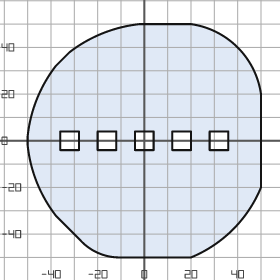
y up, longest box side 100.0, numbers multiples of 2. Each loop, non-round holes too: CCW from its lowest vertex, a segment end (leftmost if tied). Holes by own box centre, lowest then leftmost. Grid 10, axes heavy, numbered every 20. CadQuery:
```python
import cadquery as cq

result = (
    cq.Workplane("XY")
    .moveTo(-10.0, -50.0)
    .lineTo(20.0, -50.0)
    .threePointArc((38.0, -38.0), (50.0, -20.0))
    .lineTo(50.0, 20.0)
    .threePointArc((40.0, 40.0), (20.0, 50.0))
    .lineTo(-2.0, 50.0)
    .threePointArc((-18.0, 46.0), (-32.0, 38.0))
    .lineTo(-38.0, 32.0)
    .threePointArc((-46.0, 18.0), (-50.0, 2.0))
    .lineTo(-50.0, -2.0)
    .threePointArc((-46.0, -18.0), (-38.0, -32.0))
    .lineTo(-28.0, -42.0)
    .threePointArc((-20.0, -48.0), (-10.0, -50.0))
    .close()
    .moveTo(-36.0, -4.0)
    .lineTo(-28.0, -4.0)
    .lineTo(-28.0, 4.0)
    .lineTo(-36.0, 4.0)
    .close()
    .moveTo(-20.0, -4.0)
    .lineTo(-12.0, -4.0)
    .lineTo(-12.0, 4.0)
    .lineTo(-20.0, 4.0)
    .close()
    .moveTo(-4.0, -4.0)
    .lineTo(4.0, -4.0)
    .lineTo(4.0, 4.0)
    .lineTo(-4.0, 4.0)
    .close()
    .moveTo(12.0, -4.0)
    .lineTo(20.0, -4.0)
    .lineTo(20.0, 4.0)
    .lineTo(12.0, 4.0)
    .close()
    .moveTo(28.0, -4.0)
    .lineTo(36.0, -4.0)
    .lineTo(36.0, 4.0)
    .lineTo(28.0, 4.0)
    .close()
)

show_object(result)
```